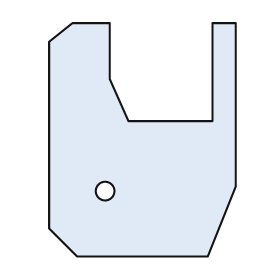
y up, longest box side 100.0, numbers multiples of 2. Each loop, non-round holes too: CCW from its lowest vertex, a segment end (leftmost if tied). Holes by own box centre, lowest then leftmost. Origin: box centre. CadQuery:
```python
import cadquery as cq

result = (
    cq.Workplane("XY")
    .moveTo(-28.0, -50.0)
    .lineTo(28.0, -50.0)
    .lineTo(40.0, -20.0)
    .lineTo(40.0, 50.0)
    .lineTo(30.0, 50.0)
    .lineTo(30.0, 8.0)
    .lineTo(-6.0, 8.0)
    .lineTo(-14.0, 26.0)
    .lineTo(-14.0, 50.0)
    .lineTo(-30.0, 50.0)
    .lineTo(-40.0, 42.0)
    .lineTo(-40.0, -38.0)
    .close()
    .moveTo(-16.0, -22.0)
    .circle(4.0)
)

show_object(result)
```